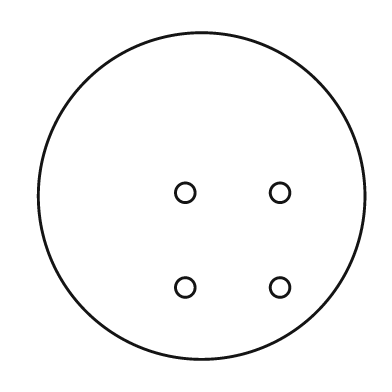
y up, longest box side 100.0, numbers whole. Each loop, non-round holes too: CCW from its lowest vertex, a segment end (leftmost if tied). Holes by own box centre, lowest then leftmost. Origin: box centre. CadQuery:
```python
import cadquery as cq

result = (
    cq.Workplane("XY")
    .moveTo(0.0, 0.0)
    .circle(50.0)
    .moveTo(-5.0, -28.0)
    .circle(3.0)
    .moveTo(24.0, -28.0)
    .circle(3.0)
    .moveTo(-5.0, 1.0)
    .circle(3.0)
    .moveTo(24.0, 1.0)
    .circle(3.0)
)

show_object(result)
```